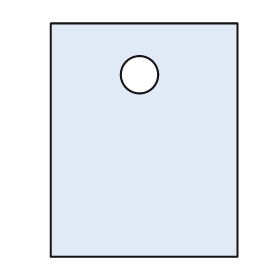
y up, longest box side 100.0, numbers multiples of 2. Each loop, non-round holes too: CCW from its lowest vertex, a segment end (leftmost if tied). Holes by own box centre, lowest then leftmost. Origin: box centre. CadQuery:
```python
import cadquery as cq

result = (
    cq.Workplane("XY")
    .moveTo(-40.0, -50.0)
    .lineTo(40.0, -50.0)
    .lineTo(40.0, 50.0)
    .lineTo(-40.0, 50.0)
    .close()
    .moveTo(-2.0, 28.0)
    .circle(8.0)
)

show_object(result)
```